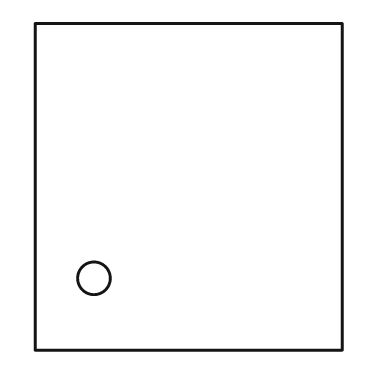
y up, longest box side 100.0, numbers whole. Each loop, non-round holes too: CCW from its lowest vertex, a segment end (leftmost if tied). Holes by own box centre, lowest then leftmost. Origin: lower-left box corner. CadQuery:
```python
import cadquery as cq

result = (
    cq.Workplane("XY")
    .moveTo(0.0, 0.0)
    .lineTo(94.0, 0.0)
    .lineTo(94.0, 100.0)
    .lineTo(0.0, 100.0)
    .close()
    .moveTo(18.0, 22.0)
    .circle(5.0)
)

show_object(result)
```